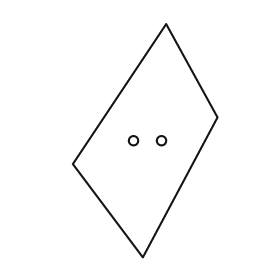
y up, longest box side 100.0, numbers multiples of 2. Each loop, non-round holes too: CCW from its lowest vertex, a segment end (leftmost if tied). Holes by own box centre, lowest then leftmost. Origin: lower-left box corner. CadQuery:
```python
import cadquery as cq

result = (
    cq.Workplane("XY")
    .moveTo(30.0, 0.0)
    .lineTo(62.0, 60.0)
    .lineTo(40.0, 100.0)
    .lineTo(0.0, 40.0)
    .close()
    .moveTo(26.0, 50.0)
    .circle(2.0)
    .moveTo(38.0, 50.0)
    .circle(2.0)
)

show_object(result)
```